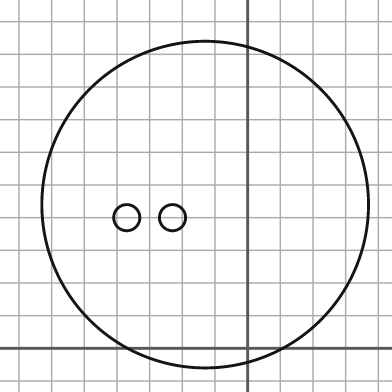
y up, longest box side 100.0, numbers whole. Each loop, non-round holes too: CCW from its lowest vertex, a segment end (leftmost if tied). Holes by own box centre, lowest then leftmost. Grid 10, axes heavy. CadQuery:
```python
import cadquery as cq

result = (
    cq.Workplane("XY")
    .moveTo(-13.0, 44.0)
    .circle(50.0)
    .moveTo(-37.0, 40.0)
    .circle(4.0)
    .moveTo(-23.0, 40.0)
    .circle(4.0)
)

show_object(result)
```